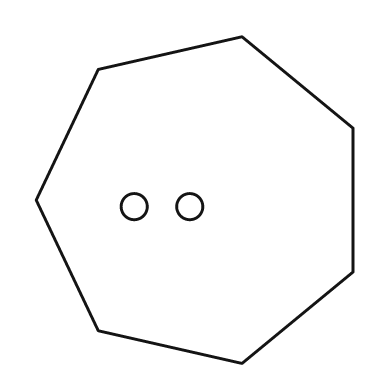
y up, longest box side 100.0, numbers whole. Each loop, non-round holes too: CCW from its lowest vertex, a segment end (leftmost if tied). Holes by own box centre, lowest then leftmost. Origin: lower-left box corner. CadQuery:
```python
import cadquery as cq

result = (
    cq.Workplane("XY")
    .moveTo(63.0, 0.0)
    .lineTo(97.0, 28.0)
    .lineTo(97.0, 72.0)
    .lineTo(63.0, 100.0)
    .lineTo(19.0, 90.0)
    .lineTo(0.0, 50.0)
    .lineTo(19.0, 10.0)
    .close()
    .moveTo(30.0, 48.0)
    .circle(4.0)
    .moveTo(47.0, 48.0)
    .circle(4.0)
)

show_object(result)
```